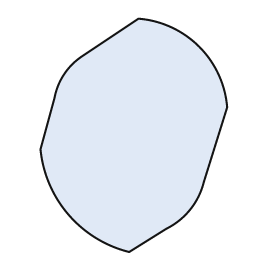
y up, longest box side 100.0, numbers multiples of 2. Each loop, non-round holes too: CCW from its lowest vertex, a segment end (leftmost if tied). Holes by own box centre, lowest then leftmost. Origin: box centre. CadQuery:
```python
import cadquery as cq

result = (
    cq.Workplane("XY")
    .moveTo(-2.0, -50.0)
    .lineTo(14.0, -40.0)
    .threePointArc((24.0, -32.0), (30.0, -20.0))
    .lineTo(40.0, 12.0)
    .threePointArc((28.0, 38.0), (2.0, 50.0))
    .lineTo(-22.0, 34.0)
    .threePointArc((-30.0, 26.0), (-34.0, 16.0))
    .lineTo(-40.0, -6.0)
    .threePointArc((-28.0, -34.0), (-2.0, -50.0))
    .close()
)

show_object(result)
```